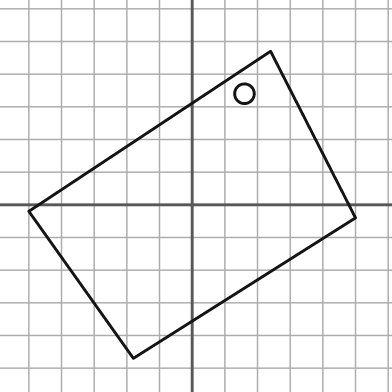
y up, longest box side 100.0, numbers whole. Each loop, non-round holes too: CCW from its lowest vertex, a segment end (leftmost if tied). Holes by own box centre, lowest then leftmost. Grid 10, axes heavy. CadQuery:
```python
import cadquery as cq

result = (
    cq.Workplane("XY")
    .moveTo(-18.0, -47.0)
    .lineTo(50.0, -4.0)
    .lineTo(24.0, 47.0)
    .lineTo(-50.0, -2.0)
    .close()
    .moveTo(16.0, 34.0)
    .circle(3.0)
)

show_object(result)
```